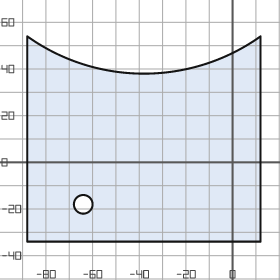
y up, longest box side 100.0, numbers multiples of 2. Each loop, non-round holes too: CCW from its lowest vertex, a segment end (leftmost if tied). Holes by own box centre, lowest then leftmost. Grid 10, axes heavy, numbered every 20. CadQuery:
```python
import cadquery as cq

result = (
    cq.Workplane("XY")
    .moveTo(-88.0, -34.0)
    .lineTo(12.0, -34.0)
    .lineTo(12.0, 54.0)
    .threePointArc((-38.0, 38.0), (-88.0, 54.0))
    .close()
    .moveTo(-64.0, -18.0)
    .circle(4.0)
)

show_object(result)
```